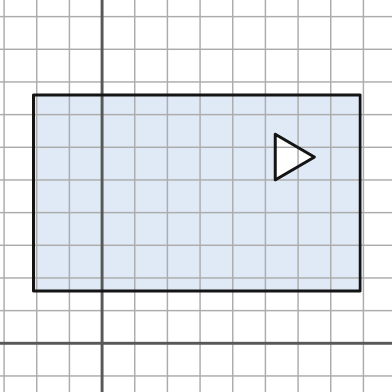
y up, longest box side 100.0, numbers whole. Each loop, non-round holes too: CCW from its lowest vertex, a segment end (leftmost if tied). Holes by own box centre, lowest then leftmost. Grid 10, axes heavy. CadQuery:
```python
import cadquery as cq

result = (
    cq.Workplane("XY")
    .moveTo(-21.0, 16.0)
    .lineTo(79.0, 16.0)
    .lineTo(79.0, 76.0)
    .lineTo(-21.0, 76.0)
    .close()
    .moveTo(53.0, 50.0)
    .lineTo(65.0, 57.0)
    .lineTo(53.0, 64.0)
    .close()
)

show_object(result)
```